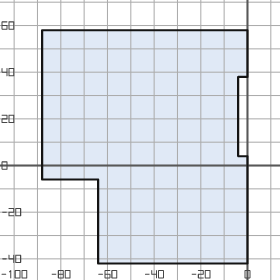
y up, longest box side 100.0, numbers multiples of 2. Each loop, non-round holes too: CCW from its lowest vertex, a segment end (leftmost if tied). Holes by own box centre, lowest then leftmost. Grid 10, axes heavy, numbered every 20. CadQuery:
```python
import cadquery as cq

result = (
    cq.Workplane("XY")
    .moveTo(-64.0, -42.0)
    .lineTo(0.0, -42.0)
    .lineTo(0.0, 4.0)
    .lineTo(-4.0, 4.0)
    .lineTo(-4.0, 38.0)
    .lineTo(0.0, 38.0)
    .lineTo(0.0, 58.0)
    .lineTo(-88.0, 58.0)
    .lineTo(-88.0, -6.0)
    .lineTo(-64.0, -6.0)
    .close()
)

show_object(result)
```